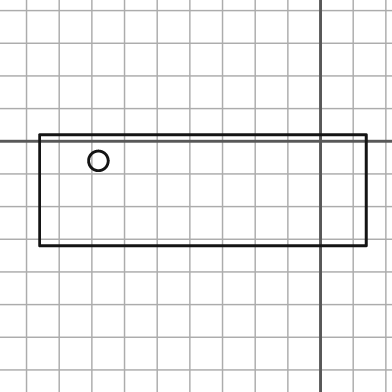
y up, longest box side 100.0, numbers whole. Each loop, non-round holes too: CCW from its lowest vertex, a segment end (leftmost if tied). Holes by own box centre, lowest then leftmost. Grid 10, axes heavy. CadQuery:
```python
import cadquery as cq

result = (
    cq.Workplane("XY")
    .moveTo(-86.0, -32.0)
    .lineTo(14.0, -32.0)
    .lineTo(14.0, 2.0)
    .lineTo(-86.0, 2.0)
    .close()
    .moveTo(-68.0, -6.0)
    .circle(3.0)
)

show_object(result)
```